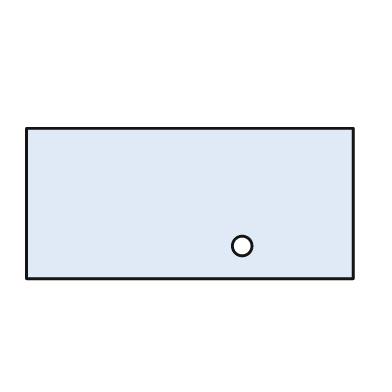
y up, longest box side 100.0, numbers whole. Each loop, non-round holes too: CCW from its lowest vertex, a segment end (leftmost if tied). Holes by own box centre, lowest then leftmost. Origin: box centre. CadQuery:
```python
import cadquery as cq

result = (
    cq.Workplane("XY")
    .moveTo(-50.0, -23.0)
    .lineTo(50.0, -23.0)
    .lineTo(50.0, 23.0)
    .lineTo(-50.0, 23.0)
    .close()
    .moveTo(16.0, -13.0)
    .circle(3.0)
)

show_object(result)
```